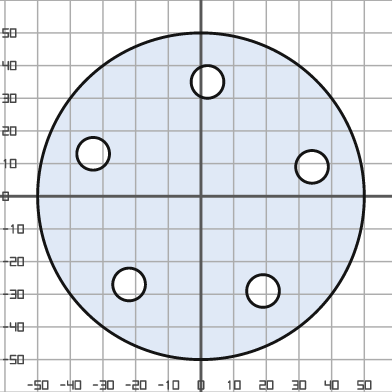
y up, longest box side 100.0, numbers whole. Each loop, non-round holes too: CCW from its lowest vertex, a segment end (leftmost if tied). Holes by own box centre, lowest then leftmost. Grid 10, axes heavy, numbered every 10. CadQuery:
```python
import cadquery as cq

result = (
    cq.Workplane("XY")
    .moveTo(0.0, 0.0)
    .circle(50.0)
    .moveTo(19.0, -29.0)
    .circle(5.0)
    .moveTo(-22.0, -27.0)
    .circle(5.0)
    .moveTo(34.0, 9.0)
    .circle(5.0)
    .moveTo(-33.0, 13.0)
    .circle(5.0)
    .moveTo(2.0, 35.0)
    .circle(5.0)
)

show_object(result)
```